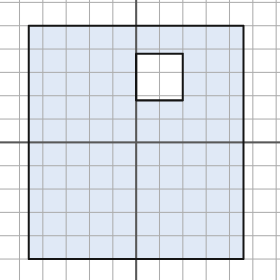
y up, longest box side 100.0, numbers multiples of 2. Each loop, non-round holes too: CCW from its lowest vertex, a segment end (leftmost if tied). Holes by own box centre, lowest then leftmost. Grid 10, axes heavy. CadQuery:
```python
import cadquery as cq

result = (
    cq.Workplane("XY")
    .moveTo(-46.0, -50.0)
    .lineTo(46.0, -50.0)
    .lineTo(46.0, 50.0)
    .lineTo(-46.0, 50.0)
    .close()
    .moveTo(0.0, 18.0)
    .lineTo(20.0, 18.0)
    .lineTo(20.0, 38.0)
    .lineTo(0.0, 38.0)
    .close()
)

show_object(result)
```